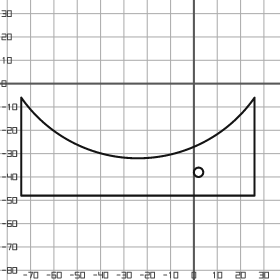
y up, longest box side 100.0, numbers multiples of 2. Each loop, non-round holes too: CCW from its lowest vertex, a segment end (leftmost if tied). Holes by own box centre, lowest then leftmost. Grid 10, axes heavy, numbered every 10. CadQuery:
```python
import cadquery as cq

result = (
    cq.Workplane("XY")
    .moveTo(-74.0, -48.0)
    .lineTo(26.0, -48.0)
    .lineTo(26.0, -6.0)
    .threePointArc((-24.0, -32.0), (-74.0, -6.0))
    .close()
    .moveTo(2.0, -38.0)
    .circle(2.0)
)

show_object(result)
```